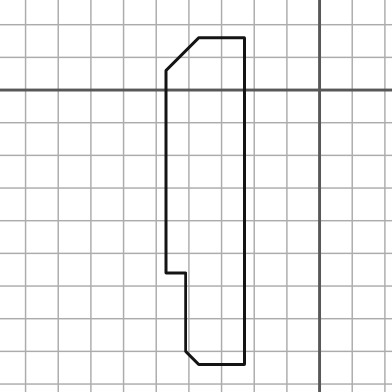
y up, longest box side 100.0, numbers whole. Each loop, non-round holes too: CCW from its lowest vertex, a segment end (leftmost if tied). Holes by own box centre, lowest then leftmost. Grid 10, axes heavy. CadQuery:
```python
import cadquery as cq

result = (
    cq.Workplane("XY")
    .moveTo(-37.0, -84.0)
    .lineTo(-23.0, -84.0)
    .lineTo(-23.0, 16.0)
    .lineTo(-37.0, 16.0)
    .lineTo(-47.0, 6.0)
    .lineTo(-47.0, -56.0)
    .lineTo(-41.0, -56.0)
    .lineTo(-41.0, -80.0)
    .close()
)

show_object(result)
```